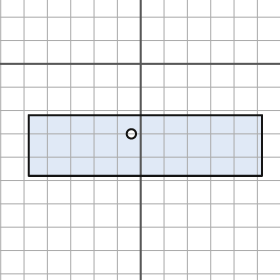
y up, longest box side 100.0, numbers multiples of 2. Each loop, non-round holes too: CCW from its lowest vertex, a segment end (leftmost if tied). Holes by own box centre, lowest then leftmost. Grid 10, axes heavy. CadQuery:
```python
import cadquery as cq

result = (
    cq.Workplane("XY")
    .moveTo(-48.0, -48.0)
    .lineTo(52.0, -48.0)
    .lineTo(52.0, -22.0)
    .lineTo(-48.0, -22.0)
    .close()
    .moveTo(-4.0, -30.0)
    .circle(2.0)
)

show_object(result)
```